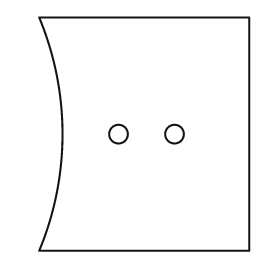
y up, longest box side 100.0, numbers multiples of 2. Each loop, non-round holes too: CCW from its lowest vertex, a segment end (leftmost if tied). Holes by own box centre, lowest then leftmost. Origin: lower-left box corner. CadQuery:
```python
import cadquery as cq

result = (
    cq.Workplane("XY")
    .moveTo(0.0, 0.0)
    .lineTo(90.0, 0.0)
    .lineTo(90.0, 100.0)
    .lineTo(0.0, 100.0)
    .threePointArc((10.0, 50.0), (0.0, 0.0))
    .close()
    .moveTo(34.0, 50.0)
    .circle(4.0)
    .moveTo(58.0, 50.0)
    .circle(4.0)
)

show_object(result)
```